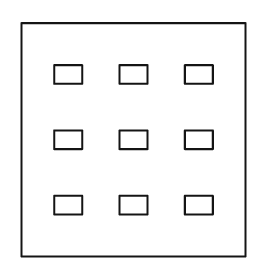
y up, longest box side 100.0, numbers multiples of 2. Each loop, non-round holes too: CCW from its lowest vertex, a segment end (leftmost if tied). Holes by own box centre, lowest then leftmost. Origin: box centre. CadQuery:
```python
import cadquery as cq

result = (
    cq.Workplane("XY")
    .moveTo(-48.0, -50.0)
    .lineTo(48.0, -50.0)
    .lineTo(48.0, 50.0)
    .lineTo(-48.0, 50.0)
    .close()
    .moveTo(-34.0, -32.0)
    .lineTo(-22.0, -32.0)
    .lineTo(-22.0, -24.0)
    .lineTo(-34.0, -24.0)
    .close()
    .moveTo(-6.0, -32.0)
    .lineTo(6.0, -32.0)
    .lineTo(6.0, -24.0)
    .lineTo(-6.0, -24.0)
    .close()
    .moveTo(22.0, -32.0)
    .lineTo(34.0, -32.0)
    .lineTo(34.0, -24.0)
    .lineTo(22.0, -24.0)
    .close()
    .moveTo(-34.0, -4.0)
    .lineTo(-22.0, -4.0)
    .lineTo(-22.0, 4.0)
    .lineTo(-34.0, 4.0)
    .close()
    .moveTo(-6.0, -4.0)
    .lineTo(6.0, -4.0)
    .lineTo(6.0, 4.0)
    .lineTo(-6.0, 4.0)
    .close()
    .moveTo(22.0, -4.0)
    .lineTo(34.0, -4.0)
    .lineTo(34.0, 4.0)
    .lineTo(22.0, 4.0)
    .close()
    .moveTo(-34.0, 24.0)
    .lineTo(-22.0, 24.0)
    .lineTo(-22.0, 32.0)
    .lineTo(-34.0, 32.0)
    .close()
    .moveTo(-6.0, 24.0)
    .lineTo(6.0, 24.0)
    .lineTo(6.0, 32.0)
    .lineTo(-6.0, 32.0)
    .close()
    .moveTo(22.0, 24.0)
    .lineTo(34.0, 24.0)
    .lineTo(34.0, 32.0)
    .lineTo(22.0, 32.0)
    .close()
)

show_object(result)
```